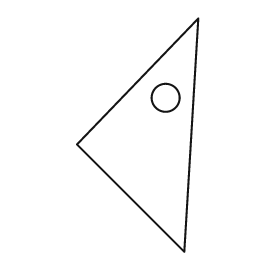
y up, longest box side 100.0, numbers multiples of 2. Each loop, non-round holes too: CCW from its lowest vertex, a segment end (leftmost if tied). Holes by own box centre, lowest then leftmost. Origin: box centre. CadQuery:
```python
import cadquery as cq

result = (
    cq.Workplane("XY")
    .moveTo(20.0, -50.0)
    .lineTo(26.0, 50.0)
    .lineTo(-26.0, -4.0)
    .close()
    .moveTo(12.0, 16.0)
    .circle(6.0)
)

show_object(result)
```